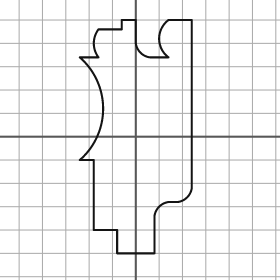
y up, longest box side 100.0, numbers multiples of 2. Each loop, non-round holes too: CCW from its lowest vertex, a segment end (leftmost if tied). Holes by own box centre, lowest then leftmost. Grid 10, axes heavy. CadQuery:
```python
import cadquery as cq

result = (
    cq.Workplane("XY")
    .moveTo(-8.0, -50.0)
    .lineTo(8.0, -50.0)
    .lineTo(8.0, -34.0)
    .threePointArc((10.0, -30.0), (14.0, -28.0))
    .lineTo(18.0, -28.0)
    .threePointArc((22.0, -26.0), (24.0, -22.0))
    .lineTo(24.0, 50.0)
    .lineTo(14.0, 50.0)
    .threePointArc((10.0, 42.0), (14.0, 34.0))
    .lineTo(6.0, 34.0)
    .threePointArc((2.0, 36.0), (0.0, 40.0))
    .lineTo(0.0, 50.0)
    .lineTo(-6.0, 50.0)
    .lineTo(-6.0, 46.0)
    .lineTo(-16.0, 46.0)
    .threePointArc((-18.0, 40.0), (-16.0, 34.0))
    .lineTo(-24.0, 34.0)
    .threePointArc((-14.0, 12.0), (-24.0, -10.0))
    .lineTo(-18.0, -10.0)
    .lineTo(-18.0, -40.0)
    .lineTo(-8.0, -40.0)
    .close()
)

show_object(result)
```